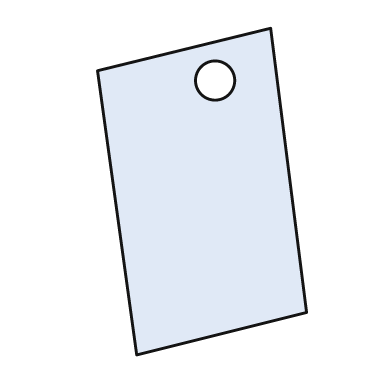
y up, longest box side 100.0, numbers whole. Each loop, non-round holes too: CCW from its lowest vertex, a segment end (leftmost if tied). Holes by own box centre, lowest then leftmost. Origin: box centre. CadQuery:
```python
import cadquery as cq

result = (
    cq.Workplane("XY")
    .moveTo(-20.0, -50.0)
    .lineTo(32.0, -37.0)
    .lineTo(21.0, 50.0)
    .lineTo(-32.0, 37.0)
    .close()
    .moveTo(4.0, 34.0)
    .circle(6.0)
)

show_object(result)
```